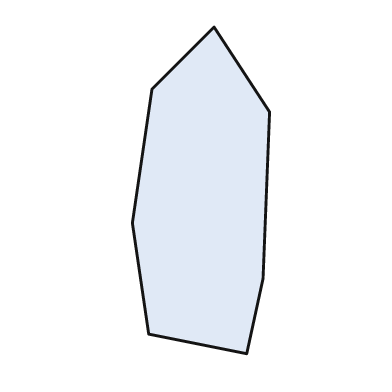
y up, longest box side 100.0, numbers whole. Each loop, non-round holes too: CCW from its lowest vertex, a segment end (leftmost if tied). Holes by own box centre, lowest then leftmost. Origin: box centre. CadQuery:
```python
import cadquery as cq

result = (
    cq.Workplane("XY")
    .moveTo(14.0, -50.0)
    .lineTo(19.0, -27.0)
    .lineTo(21.0, 24.0)
    .lineTo(4.0, 50.0)
    .lineTo(-15.0, 31.0)
    .lineTo(-21.0, -10.0)
    .lineTo(-16.0, -44.0)
    .close()
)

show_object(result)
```